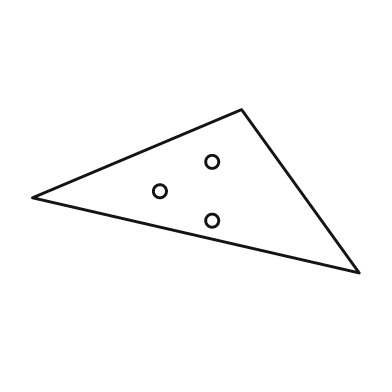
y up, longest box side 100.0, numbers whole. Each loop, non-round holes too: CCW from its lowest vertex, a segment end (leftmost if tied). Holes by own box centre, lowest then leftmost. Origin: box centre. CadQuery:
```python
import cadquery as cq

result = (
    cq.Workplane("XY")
    .moveTo(50.0, -25.0)
    .lineTo(14.0, 25.0)
    .lineTo(-50.0, -2.0)
    .close()
    .moveTo(5.0, -9.0)
    .circle(2.0)
    .moveTo(-11.0, 0.0)
    .circle(2.0)
    .moveTo(5.0, 9.0)
    .circle(2.0)
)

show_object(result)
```